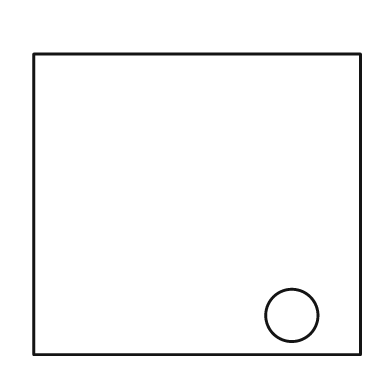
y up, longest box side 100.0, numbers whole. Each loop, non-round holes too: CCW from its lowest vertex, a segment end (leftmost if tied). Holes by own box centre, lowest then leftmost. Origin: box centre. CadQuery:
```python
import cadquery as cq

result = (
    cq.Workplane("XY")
    .moveTo(-50.0, -46.0)
    .lineTo(50.0, -46.0)
    .lineTo(50.0, 46.0)
    .lineTo(-50.0, 46.0)
    .close()
    .moveTo(29.0, -34.0)
    .circle(8.0)
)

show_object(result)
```